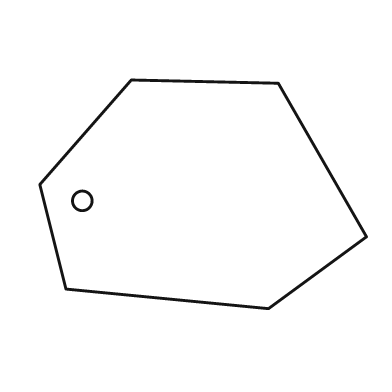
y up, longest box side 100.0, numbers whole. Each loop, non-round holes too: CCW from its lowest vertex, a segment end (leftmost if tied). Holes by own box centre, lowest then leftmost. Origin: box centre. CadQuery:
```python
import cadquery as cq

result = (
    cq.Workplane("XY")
    .moveTo(20.0, -35.0)
    .lineTo(50.0, -13.0)
    .lineTo(23.0, 34.0)
    .lineTo(-22.0, 35.0)
    .lineTo(-50.0, 3.0)
    .lineTo(-42.0, -29.0)
    .close()
    .moveTo(-37.0, -2.0)
    .circle(3.0)
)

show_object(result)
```